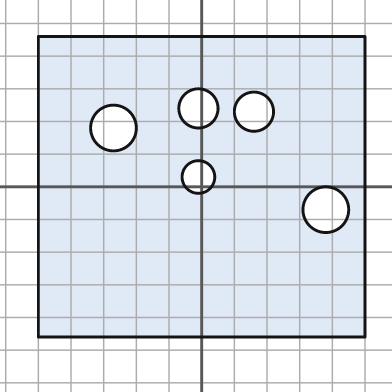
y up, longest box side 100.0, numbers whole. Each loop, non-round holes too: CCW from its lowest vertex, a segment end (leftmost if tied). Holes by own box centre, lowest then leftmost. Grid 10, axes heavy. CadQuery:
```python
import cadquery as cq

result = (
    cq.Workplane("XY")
    .moveTo(-50.0, -46.0)
    .lineTo(50.0, -46.0)
    .lineTo(50.0, 46.0)
    .lineTo(-50.0, 46.0)
    .close()
    .moveTo(38.0, -7.0)
    .circle(7.0)
    .moveTo(-1.0, 3.0)
    .circle(5.0)
    .moveTo(-27.0, 18.0)
    .circle(7.0)
    .moveTo(16.0, 23.0)
    .circle(6.0)
    .moveTo(-1.0, 24.0)
    .circle(6.0)
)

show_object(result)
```